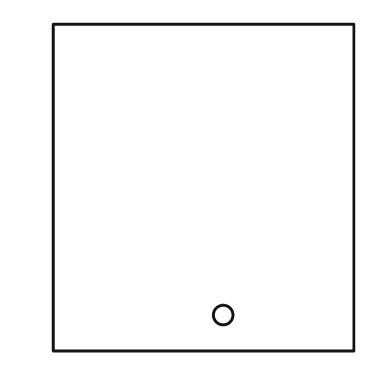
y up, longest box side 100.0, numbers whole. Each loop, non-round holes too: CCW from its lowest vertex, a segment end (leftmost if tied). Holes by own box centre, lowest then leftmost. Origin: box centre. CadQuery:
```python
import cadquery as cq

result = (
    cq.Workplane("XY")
    .moveTo(-46.0, -50.0)
    .lineTo(46.0, -50.0)
    .lineTo(46.0, 50.0)
    .lineTo(-46.0, 50.0)
    .close()
    .moveTo(6.0, -39.0)
    .circle(3.0)
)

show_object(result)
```